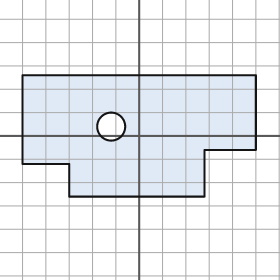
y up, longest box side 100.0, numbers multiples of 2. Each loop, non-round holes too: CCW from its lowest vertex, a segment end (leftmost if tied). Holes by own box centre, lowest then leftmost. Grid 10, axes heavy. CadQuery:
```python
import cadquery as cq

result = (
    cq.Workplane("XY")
    .moveTo(-30.0, -26.0)
    .lineTo(28.0, -26.0)
    .lineTo(28.0, -6.0)
    .lineTo(50.0, -6.0)
    .lineTo(50.0, 26.0)
    .lineTo(-50.0, 26.0)
    .lineTo(-50.0, -12.0)
    .lineTo(-30.0, -12.0)
    .close()
    .moveTo(-12.0, 4.0)
    .circle(6.0)
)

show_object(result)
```